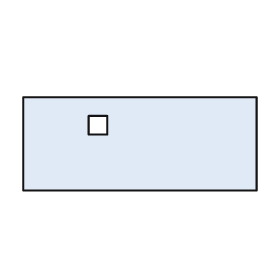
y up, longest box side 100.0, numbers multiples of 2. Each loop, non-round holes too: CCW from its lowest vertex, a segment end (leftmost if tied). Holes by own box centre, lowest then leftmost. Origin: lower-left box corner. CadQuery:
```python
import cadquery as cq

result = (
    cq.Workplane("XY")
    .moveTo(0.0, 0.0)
    .lineTo(100.0, 0.0)
    .lineTo(100.0, 40.0)
    .lineTo(0.0, 40.0)
    .close()
    .moveTo(28.0, 24.0)
    .lineTo(36.0, 24.0)
    .lineTo(36.0, 32.0)
    .lineTo(28.0, 32.0)
    .close()
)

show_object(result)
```